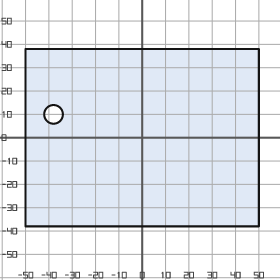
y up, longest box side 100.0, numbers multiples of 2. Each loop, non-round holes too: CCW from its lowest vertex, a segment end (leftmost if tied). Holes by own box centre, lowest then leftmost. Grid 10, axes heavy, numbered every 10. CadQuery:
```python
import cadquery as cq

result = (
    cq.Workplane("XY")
    .moveTo(-50.0, -38.0)
    .lineTo(50.0, -38.0)
    .lineTo(50.0, 38.0)
    .lineTo(-50.0, 38.0)
    .close()
    .moveTo(-38.0, 10.0)
    .circle(4.0)
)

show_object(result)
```